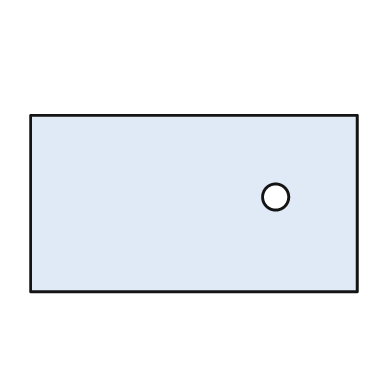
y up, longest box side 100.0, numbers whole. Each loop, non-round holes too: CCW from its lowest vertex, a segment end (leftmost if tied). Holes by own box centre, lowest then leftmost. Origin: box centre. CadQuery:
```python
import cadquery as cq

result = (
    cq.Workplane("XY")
    .moveTo(-50.0, -27.0)
    .lineTo(50.0, -27.0)
    .lineTo(50.0, 27.0)
    .lineTo(-50.0, 27.0)
    .close()
    .moveTo(25.0, 2.0)
    .circle(4.0)
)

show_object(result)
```